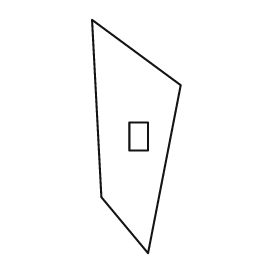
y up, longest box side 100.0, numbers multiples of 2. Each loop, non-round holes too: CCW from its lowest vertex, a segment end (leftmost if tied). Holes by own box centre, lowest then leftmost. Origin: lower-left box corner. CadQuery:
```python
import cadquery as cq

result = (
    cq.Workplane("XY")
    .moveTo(24.0, 0.0)
    .lineTo(38.0, 72.0)
    .lineTo(0.0, 100.0)
    .lineTo(4.0, 24.0)
    .close()
    .moveTo(16.0, 44.0)
    .lineTo(24.0, 44.0)
    .lineTo(24.0, 56.0)
    .lineTo(16.0, 56.0)
    .close()
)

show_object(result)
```